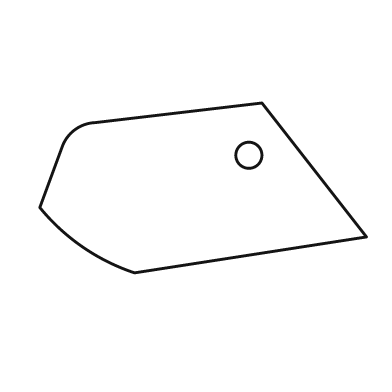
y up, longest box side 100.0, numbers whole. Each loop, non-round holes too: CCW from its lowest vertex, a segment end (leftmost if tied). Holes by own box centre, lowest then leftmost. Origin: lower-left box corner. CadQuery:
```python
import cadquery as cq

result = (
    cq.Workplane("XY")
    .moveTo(29.0, 0.0)
    .lineTo(100.0, 11.0)
    .lineTo(68.0, 52.0)
    .lineTo(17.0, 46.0)
    .threePointArc((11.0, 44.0), (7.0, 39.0))
    .lineTo(0.0, 20.0)
    .threePointArc((13.0, 8.0), (29.0, 0.0))
    .close()
    .moveTo(64.0, 36.0)
    .circle(4.0)
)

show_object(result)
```